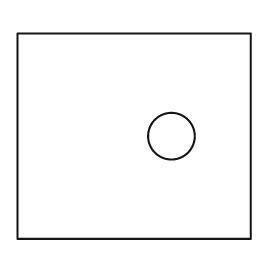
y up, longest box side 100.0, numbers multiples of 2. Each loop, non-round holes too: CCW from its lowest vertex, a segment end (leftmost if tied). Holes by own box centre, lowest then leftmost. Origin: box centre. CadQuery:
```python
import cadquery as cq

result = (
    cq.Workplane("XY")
    .moveTo(-50.0, -44.0)
    .lineTo(50.0, -44.0)
    .lineTo(50.0, 44.0)
    .lineTo(-50.0, 44.0)
    .close()
    .moveTo(16.0, 0.0)
    .circle(10.0)
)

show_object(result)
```